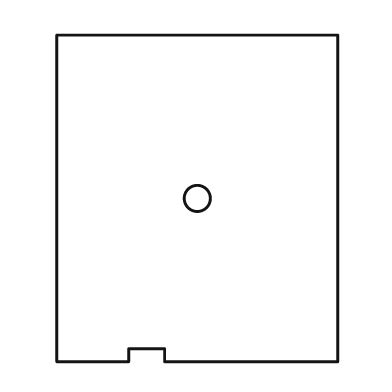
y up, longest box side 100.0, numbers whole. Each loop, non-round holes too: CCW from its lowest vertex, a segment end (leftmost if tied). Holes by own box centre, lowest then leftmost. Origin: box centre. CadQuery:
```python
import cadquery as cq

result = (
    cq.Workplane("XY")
    .moveTo(-43.0, -50.0)
    .lineTo(-21.0, -50.0)
    .lineTo(-21.0, -46.0)
    .lineTo(-10.0, -46.0)
    .lineTo(-10.0, -50.0)
    .lineTo(43.0, -50.0)
    .lineTo(43.0, 50.0)
    .lineTo(-43.0, 50.0)
    .close()
    .moveTo(0.0, 0.0)
    .circle(4.0)
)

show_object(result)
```